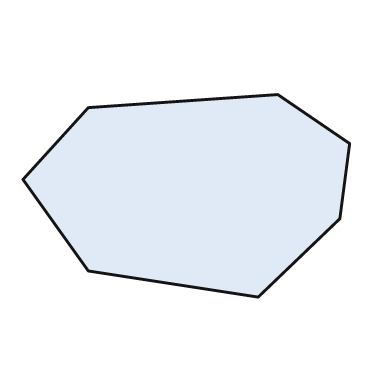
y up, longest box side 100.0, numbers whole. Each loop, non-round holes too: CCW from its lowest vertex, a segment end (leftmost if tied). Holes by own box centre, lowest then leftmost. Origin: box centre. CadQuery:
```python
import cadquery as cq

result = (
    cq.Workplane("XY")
    .moveTo(22.0, -31.0)
    .lineTo(47.0, -7.0)
    .lineTo(50.0, 16.0)
    .lineTo(28.0, 31.0)
    .lineTo(-30.0, 27.0)
    .lineTo(-50.0, 5.0)
    .lineTo(-30.0, -23.0)
    .close()
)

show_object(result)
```